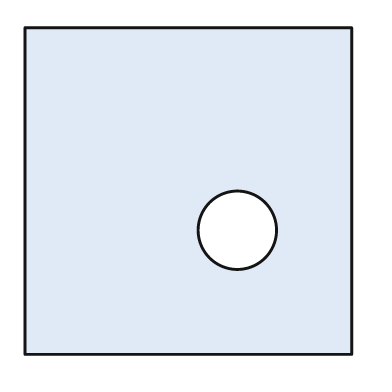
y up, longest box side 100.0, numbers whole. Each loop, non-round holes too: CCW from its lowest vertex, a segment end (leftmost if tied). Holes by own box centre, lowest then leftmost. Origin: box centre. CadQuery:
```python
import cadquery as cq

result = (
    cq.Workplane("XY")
    .moveTo(-50.0, -50.0)
    .lineTo(50.0, -50.0)
    .lineTo(50.0, 50.0)
    .lineTo(-50.0, 50.0)
    .close()
    .moveTo(15.0, -12.0)
    .circle(12.0)
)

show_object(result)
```